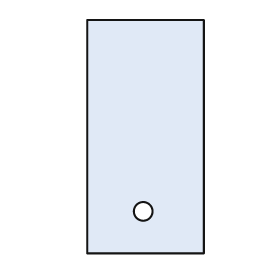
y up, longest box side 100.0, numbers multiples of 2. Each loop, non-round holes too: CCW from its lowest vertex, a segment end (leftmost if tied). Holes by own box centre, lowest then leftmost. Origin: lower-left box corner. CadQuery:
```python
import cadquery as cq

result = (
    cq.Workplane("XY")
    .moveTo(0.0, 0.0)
    .lineTo(50.0, 0.0)
    .lineTo(50.0, 100.0)
    .lineTo(0.0, 100.0)
    .close()
    .moveTo(24.0, 18.0)
    .circle(4.0)
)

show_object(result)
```